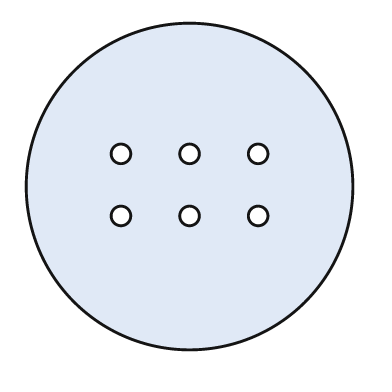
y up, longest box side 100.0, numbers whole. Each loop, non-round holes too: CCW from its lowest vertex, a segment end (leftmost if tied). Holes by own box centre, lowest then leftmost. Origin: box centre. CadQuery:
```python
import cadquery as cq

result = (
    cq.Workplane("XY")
    .moveTo(0.0, 0.0)
    .circle(50.0)
    .moveTo(-21.0, -9.0)
    .circle(3.0)
    .moveTo(0.0, -9.0)
    .circle(3.0)
    .moveTo(21.0, -9.0)
    .circle(3.0)
    .moveTo(-21.0, 10.0)
    .circle(3.0)
    .moveTo(0.0, 10.0)
    .circle(3.0)
    .moveTo(21.0, 10.0)
    .circle(3.0)
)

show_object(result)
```